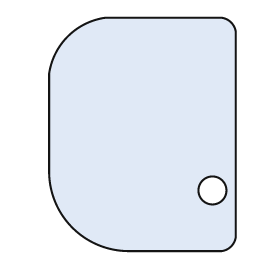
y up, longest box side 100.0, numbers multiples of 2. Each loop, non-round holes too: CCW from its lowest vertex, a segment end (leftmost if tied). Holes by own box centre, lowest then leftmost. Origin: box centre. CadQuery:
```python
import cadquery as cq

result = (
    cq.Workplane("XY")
    .moveTo(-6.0, -50.0)
    .lineTo(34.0, -50.0)
    .threePointArc((38.0, -48.0), (40.0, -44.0))
    .lineTo(40.0, 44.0)
    .threePointArc((38.0, 48.0), (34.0, 50.0))
    .lineTo(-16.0, 50.0)
    .threePointArc((-32.0, 42.0), (-40.0, 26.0))
    .lineTo(-40.0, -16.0)
    .threePointArc((-30.0, -40.0), (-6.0, -50.0))
    .close()
    .moveTo(30.0, -24.0)
    .circle(6.0)
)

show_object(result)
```